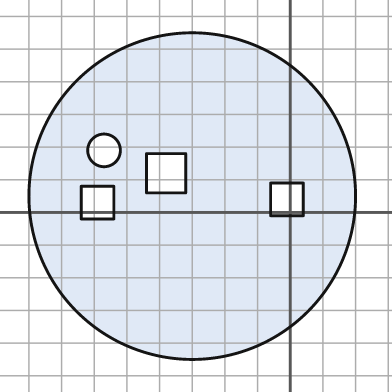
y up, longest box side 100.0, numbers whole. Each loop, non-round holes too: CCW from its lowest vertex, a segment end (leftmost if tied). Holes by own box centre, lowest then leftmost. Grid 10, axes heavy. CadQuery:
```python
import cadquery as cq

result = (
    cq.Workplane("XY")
    .moveTo(-30.0, 5.0)
    .circle(50.0)
    .moveTo(-64.0, -2.0)
    .lineTo(-54.0, -2.0)
    .lineTo(-54.0, 8.0)
    .lineTo(-64.0, 8.0)
    .close()
    .moveTo(-6.0, -1.0)
    .lineTo(4.0, -1.0)
    .lineTo(4.0, 9.0)
    .lineTo(-6.0, 9.0)
    .close()
    .moveTo(-44.0, 6.0)
    .lineTo(-32.0, 6.0)
    .lineTo(-32.0, 18.0)
    .lineTo(-44.0, 18.0)
    .close()
    .moveTo(-57.0, 19.0)
    .circle(5.0)
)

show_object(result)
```